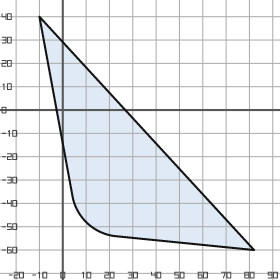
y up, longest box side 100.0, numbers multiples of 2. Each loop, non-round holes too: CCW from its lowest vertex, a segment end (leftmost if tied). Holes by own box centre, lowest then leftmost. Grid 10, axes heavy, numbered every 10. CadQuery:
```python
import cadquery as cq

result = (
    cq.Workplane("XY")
    .moveTo(82.0, -60.0)
    .lineTo(-10.0, 40.0)
    .lineTo(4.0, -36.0)
    .threePointArc((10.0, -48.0), (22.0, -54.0))
    .close()
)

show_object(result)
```